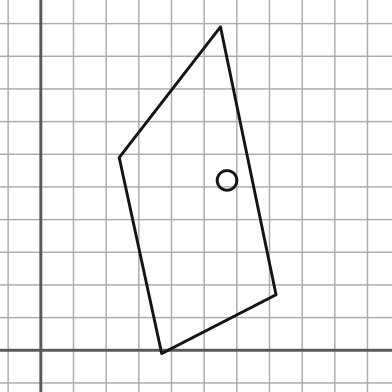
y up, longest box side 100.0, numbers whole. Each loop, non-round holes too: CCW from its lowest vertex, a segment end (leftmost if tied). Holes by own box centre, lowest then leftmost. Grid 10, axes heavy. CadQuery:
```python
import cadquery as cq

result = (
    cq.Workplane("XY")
    .moveTo(37.0, -1.0)
    .lineTo(72.0, 17.0)
    .lineTo(55.0, 99.0)
    .lineTo(24.0, 59.0)
    .close()
    .moveTo(57.0, 52.0)
    .circle(3.0)
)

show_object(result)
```